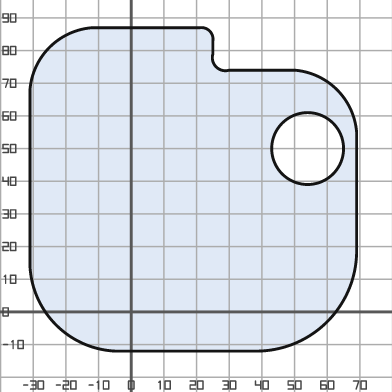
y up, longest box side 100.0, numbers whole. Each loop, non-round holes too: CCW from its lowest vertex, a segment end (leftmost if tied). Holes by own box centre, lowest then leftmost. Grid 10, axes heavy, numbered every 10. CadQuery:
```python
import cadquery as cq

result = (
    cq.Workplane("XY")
    .moveTo(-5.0, -12.0)
    .lineTo(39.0, -12.0)
    .threePointArc((60.0, -3.0), (69.0, 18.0))
    .lineTo(69.0, 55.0)
    .threePointArc((63.0, 68.0), (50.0, 74.0))
    .lineTo(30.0, 74.0)
    .threePointArc((26.0, 75.0), (25.0, 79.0))
    .lineTo(25.0, 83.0)
    .threePointArc((24.0, 86.0), (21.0, 87.0))
    .lineTo(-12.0, 87.0)
    .threePointArc((-25.0, 81.0), (-31.0, 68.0))
    .lineTo(-31.0, 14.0)
    .threePointArc((-23.0, -4.0), (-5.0, -12.0))
    .close()
    .moveTo(54.0, 50.0)
    .circle(11.0)
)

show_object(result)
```